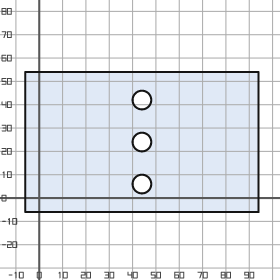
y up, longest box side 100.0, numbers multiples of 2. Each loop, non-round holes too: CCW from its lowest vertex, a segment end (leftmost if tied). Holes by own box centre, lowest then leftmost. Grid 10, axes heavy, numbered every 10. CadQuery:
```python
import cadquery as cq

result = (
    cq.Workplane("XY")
    .moveTo(-6.0, -6.0)
    .lineTo(94.0, -6.0)
    .lineTo(94.0, 54.0)
    .lineTo(-6.0, 54.0)
    .close()
    .moveTo(44.0, 6.0)
    .circle(4.0)
    .moveTo(44.0, 24.0)
    .circle(4.0)
    .moveTo(44.0, 42.0)
    .circle(4.0)
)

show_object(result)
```